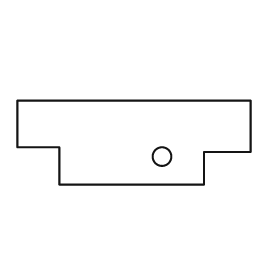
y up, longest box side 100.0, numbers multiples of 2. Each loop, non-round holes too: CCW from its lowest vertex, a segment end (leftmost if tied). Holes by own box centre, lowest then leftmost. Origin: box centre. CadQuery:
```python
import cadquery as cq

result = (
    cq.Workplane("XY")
    .moveTo(-32.0, -18.0)
    .lineTo(30.0, -18.0)
    .lineTo(30.0, -4.0)
    .lineTo(50.0, -4.0)
    .lineTo(50.0, 18.0)
    .lineTo(-50.0, 18.0)
    .lineTo(-50.0, -2.0)
    .lineTo(-32.0, -2.0)
    .close()
    .moveTo(12.0, -6.0)
    .circle(4.0)
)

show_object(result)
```